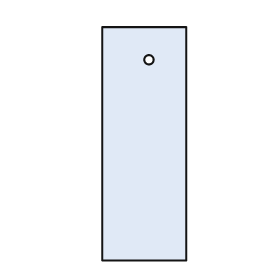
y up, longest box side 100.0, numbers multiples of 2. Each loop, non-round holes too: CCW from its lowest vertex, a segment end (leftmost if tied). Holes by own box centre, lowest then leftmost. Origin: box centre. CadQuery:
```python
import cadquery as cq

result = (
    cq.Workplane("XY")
    .moveTo(-18.0, -50.0)
    .lineTo(18.0, -50.0)
    .lineTo(18.0, 50.0)
    .lineTo(-18.0, 50.0)
    .close()
    .moveTo(2.0, 36.0)
    .circle(2.0)
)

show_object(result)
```